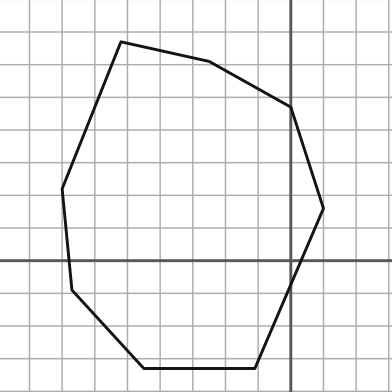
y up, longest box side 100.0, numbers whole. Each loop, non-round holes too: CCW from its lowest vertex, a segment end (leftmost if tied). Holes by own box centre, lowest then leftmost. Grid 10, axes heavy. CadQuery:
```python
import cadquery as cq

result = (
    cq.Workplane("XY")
    .moveTo(-45.0, -33.0)
    .lineTo(-11.0, -33.0)
    .lineTo(10.0, 16.0)
    .lineTo(0.0, 47.0)
    .lineTo(-25.0, 61.0)
    .lineTo(-52.0, 67.0)
    .lineTo(-70.0, 22.0)
    .lineTo(-67.0, -9.0)
    .close()
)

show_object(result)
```